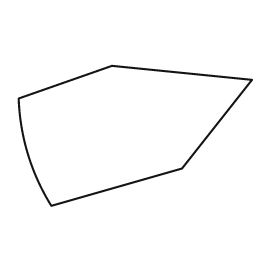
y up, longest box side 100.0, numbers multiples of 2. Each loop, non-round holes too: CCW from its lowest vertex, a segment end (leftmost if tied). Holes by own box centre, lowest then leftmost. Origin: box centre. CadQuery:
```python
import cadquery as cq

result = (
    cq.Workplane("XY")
    .moveTo(-36.0, -30.0)
    .lineTo(20.0, -14.0)
    .lineTo(50.0, 24.0)
    .lineTo(-10.0, 30.0)
    .lineTo(-50.0, 16.0)
    .threePointArc((-46.0, -8.0), (-36.0, -30.0))
    .close()
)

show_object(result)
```